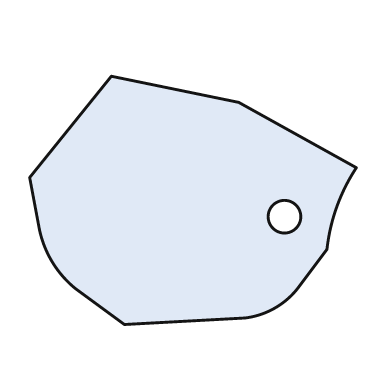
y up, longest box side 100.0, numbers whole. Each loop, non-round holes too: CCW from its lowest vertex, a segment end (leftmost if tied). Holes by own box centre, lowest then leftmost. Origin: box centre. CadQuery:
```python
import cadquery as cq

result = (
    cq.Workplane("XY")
    .moveTo(-21.0, -38.0)
    .lineTo(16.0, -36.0)
    .threePointArc((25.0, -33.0), (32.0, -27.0))
    .lineTo(41.0, -15.0)
    .threePointArc((44.0, -2.0), (50.0, 10.0))
    .lineTo(14.0, 30.0)
    .lineTo(-25.0, 38.0)
    .lineTo(-50.0, 7.0)
    .lineTo(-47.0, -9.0)
    .threePointArc((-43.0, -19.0), (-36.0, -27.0))
    .close()
    .moveTo(28.0, -5.0)
    .circle(5.0)
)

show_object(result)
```